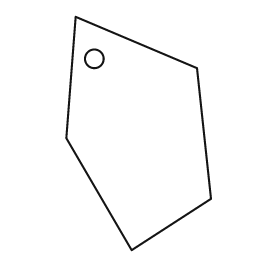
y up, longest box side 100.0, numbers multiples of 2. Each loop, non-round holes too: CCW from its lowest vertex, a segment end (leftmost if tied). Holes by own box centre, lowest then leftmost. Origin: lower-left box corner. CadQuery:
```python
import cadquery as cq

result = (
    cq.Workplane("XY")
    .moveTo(28.0, 0.0)
    .lineTo(62.0, 22.0)
    .lineTo(56.0, 78.0)
    .lineTo(4.0, 100.0)
    .lineTo(0.0, 48.0)
    .close()
    .moveTo(12.0, 82.0)
    .circle(4.0)
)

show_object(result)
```